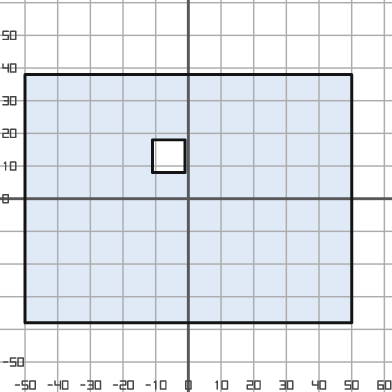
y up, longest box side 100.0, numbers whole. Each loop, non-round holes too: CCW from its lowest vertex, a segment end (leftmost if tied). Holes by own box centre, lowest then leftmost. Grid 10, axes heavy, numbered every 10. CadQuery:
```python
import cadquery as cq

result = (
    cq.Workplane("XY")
    .moveTo(-50.0, -38.0)
    .lineTo(50.0, -38.0)
    .lineTo(50.0, 38.0)
    .lineTo(-50.0, 38.0)
    .close()
    .moveTo(-11.0, 8.0)
    .lineTo(-1.0, 8.0)
    .lineTo(-1.0, 18.0)
    .lineTo(-11.0, 18.0)
    .close()
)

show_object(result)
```